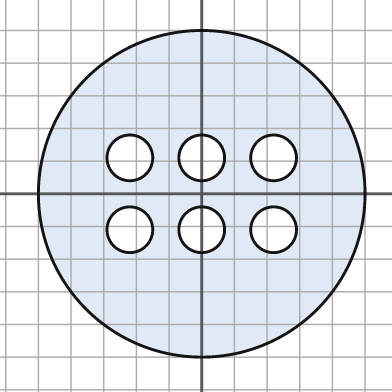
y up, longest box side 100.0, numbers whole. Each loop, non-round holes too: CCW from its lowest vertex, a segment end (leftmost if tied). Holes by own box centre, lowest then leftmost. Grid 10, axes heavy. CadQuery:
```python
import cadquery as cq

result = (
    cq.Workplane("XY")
    .moveTo(0.0, 0.0)
    .circle(50.0)
    .moveTo(-22.0, -11.0)
    .circle(7.0)
    .moveTo(0.0, -11.0)
    .circle(7.0)
    .moveTo(22.0, -11.0)
    .circle(7.0)
    .moveTo(-22.0, 11.0)
    .circle(7.0)
    .moveTo(0.0, 11.0)
    .circle(7.0)
    .moveTo(22.0, 11.0)
    .circle(7.0)
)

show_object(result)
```